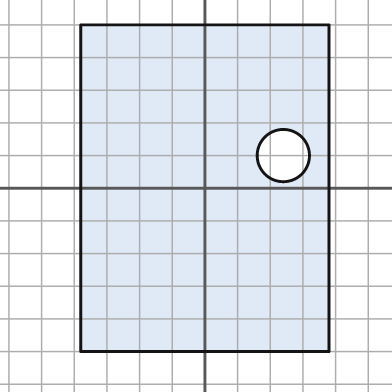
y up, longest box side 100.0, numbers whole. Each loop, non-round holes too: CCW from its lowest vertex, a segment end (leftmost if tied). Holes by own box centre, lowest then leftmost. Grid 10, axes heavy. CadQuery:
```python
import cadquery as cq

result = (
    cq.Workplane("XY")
    .moveTo(-38.0, -50.0)
    .lineTo(38.0, -50.0)
    .lineTo(38.0, 50.0)
    .lineTo(-38.0, 50.0)
    .close()
    .moveTo(24.0, 10.0)
    .circle(8.0)
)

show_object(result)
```